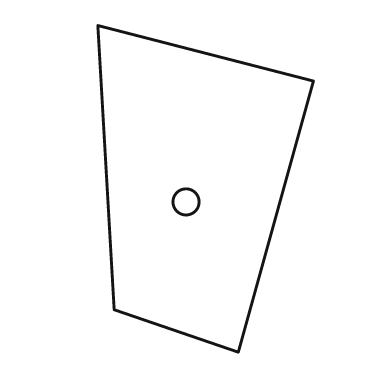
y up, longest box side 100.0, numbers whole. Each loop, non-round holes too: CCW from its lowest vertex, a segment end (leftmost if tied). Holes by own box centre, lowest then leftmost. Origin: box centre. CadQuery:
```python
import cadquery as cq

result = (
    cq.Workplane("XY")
    .moveTo(10.0, -50.0)
    .lineTo(33.0, 33.0)
    .lineTo(-33.0, 50.0)
    .lineTo(-28.0, -37.0)
    .close()
    .moveTo(-6.0, -4.0)
    .circle(4.0)
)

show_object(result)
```